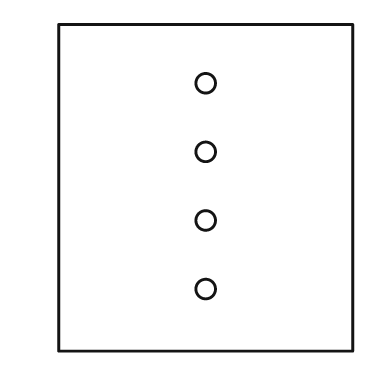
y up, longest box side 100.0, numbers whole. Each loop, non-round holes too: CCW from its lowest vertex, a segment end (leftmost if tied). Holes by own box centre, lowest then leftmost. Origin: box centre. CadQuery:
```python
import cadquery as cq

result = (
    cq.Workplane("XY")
    .moveTo(-45.0, -50.0)
    .lineTo(45.0, -50.0)
    .lineTo(45.0, 50.0)
    .lineTo(-45.0, 50.0)
    .close()
    .moveTo(0.0, -31.0)
    .circle(3.0)
    .moveTo(0.0, -10.0)
    .circle(3.0)
    .moveTo(0.0, 11.0)
    .circle(3.0)
    .moveTo(0.0, 32.0)
    .circle(3.0)
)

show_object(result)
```